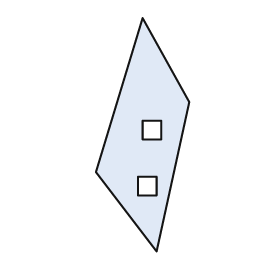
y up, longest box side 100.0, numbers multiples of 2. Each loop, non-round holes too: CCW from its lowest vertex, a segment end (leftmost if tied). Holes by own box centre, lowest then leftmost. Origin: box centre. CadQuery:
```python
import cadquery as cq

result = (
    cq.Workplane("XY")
    .moveTo(6.0, -50.0)
    .lineTo(20.0, 14.0)
    .lineTo(0.0, 50.0)
    .lineTo(-20.0, -16.0)
    .close()
    .moveTo(-2.0, -26.0)
    .lineTo(6.0, -26.0)
    .lineTo(6.0, -18.0)
    .lineTo(-2.0, -18.0)
    .close()
    .moveTo(0.0, -2.0)
    .lineTo(8.0, -2.0)
    .lineTo(8.0, 6.0)
    .lineTo(0.0, 6.0)
    .close()
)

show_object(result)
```